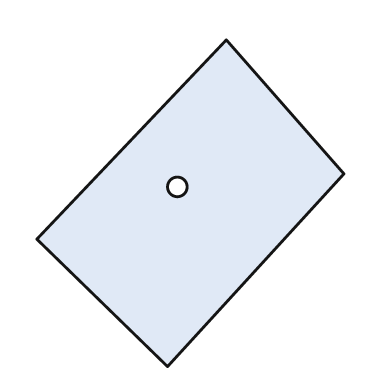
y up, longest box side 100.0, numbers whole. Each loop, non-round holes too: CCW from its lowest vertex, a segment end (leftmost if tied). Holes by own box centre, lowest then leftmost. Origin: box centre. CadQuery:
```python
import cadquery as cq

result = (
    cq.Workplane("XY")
    .moveTo(-7.0, -50.0)
    .lineTo(47.0, 9.0)
    .lineTo(11.0, 50.0)
    .lineTo(-47.0, -11.0)
    .close()
    .moveTo(-4.0, 5.0)
    .circle(3.0)
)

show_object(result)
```